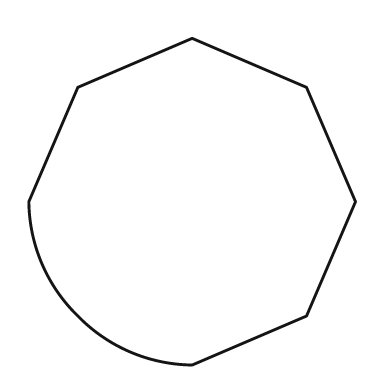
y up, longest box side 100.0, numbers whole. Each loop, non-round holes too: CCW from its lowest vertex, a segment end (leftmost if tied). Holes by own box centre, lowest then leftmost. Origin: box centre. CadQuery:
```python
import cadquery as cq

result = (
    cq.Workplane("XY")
    .moveTo(0.0, -50.0)
    .lineTo(35.0, -35.0)
    .lineTo(50.0, 0.0)
    .lineTo(35.0, 35.0)
    .lineTo(0.0, 50.0)
    .lineTo(-35.0, 35.0)
    .lineTo(-50.0, 0.0)
    .threePointArc((-46.0, -19.0), (-35.0, -35.0))
    .threePointArc((-19.0, -46.0), (0.0, -50.0))
    .close()
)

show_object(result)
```